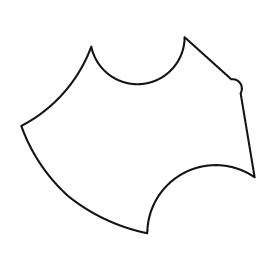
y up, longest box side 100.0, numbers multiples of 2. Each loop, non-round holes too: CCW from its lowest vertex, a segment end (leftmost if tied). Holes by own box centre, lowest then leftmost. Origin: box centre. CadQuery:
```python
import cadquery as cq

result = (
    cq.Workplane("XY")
    .moveTo(4.0, -42.0)
    .threePointArc((20.0, -16.0), (50.0, -18.0))
    .lineTo(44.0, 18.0)
    .threePointArc((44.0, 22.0), (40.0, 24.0))
    .lineTo(20.0, 42.0)
    .threePointArc((2.0, 22.0), (-20.0, 38.0))
    .threePointArc((-32.0, 18.0), (-50.0, 4.0))
    .threePointArc((-42.0, -12.0), (-30.0, -26.0))
    .threePointArc((-14.0, -36.0), (4.0, -42.0))
    .close()
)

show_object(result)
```